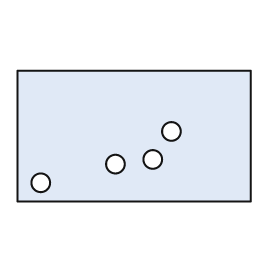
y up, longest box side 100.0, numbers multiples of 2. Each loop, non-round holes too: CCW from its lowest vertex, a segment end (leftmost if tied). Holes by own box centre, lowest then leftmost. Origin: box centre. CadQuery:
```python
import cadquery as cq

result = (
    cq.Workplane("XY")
    .moveTo(-50.0, -28.0)
    .lineTo(50.0, -28.0)
    .lineTo(50.0, 28.0)
    .lineTo(-50.0, 28.0)
    .close()
    .moveTo(-40.0, -20.0)
    .circle(4.0)
    .moveTo(-8.0, -12.0)
    .circle(4.0)
    .moveTo(8.0, -10.0)
    .circle(4.0)
    .moveTo(16.0, 2.0)
    .circle(4.0)
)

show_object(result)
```